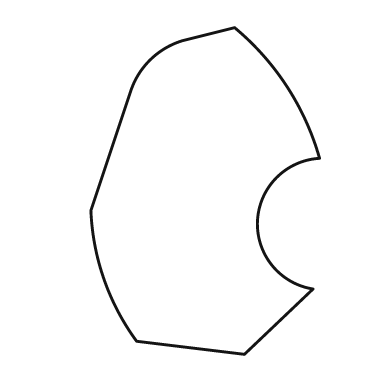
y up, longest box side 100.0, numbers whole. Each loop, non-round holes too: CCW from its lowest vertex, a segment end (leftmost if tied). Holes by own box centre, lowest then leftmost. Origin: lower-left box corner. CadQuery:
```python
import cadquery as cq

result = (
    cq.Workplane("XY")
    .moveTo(47.0, 0.0)
    .lineTo(68.0, 20.0)
    .threePointArc((51.0, 41.0), (70.0, 60.0))
    .threePointArc((60.0, 82.0), (44.0, 100.0))
    .lineTo(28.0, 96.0)
    .threePointArc((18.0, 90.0), (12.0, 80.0))
    .lineTo(0.0, 44.0)
    .threePointArc((4.0, 23.0), (14.0, 4.0))
    .close()
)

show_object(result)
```